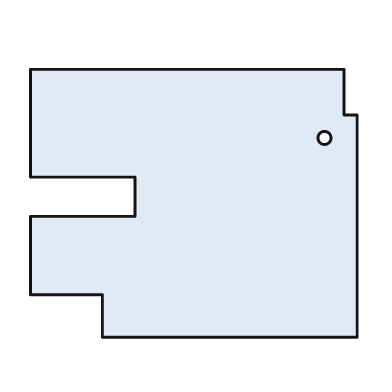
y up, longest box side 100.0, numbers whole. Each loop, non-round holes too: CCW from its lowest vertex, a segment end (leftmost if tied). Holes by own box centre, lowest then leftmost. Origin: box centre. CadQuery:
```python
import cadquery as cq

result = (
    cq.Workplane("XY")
    .moveTo(-28.0, -41.0)
    .lineTo(50.0, -41.0)
    .lineTo(50.0, 27.0)
    .lineTo(46.0, 27.0)
    .lineTo(46.0, 41.0)
    .lineTo(-50.0, 41.0)
    .lineTo(-50.0, 8.0)
    .lineTo(-18.0, 8.0)
    .lineTo(-18.0, -4.0)
    .lineTo(-50.0, -4.0)
    .lineTo(-50.0, -28.0)
    .lineTo(-28.0, -28.0)
    .close()
    .moveTo(40.0, 20.0)
    .circle(2.0)
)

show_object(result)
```